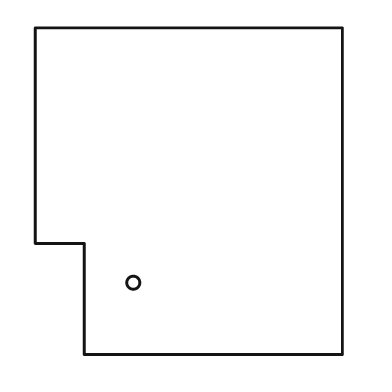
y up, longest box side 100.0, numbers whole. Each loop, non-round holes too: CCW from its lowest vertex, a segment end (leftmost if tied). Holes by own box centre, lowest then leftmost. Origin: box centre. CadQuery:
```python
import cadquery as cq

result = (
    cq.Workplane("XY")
    .moveTo(-32.0, -50.0)
    .lineTo(47.0, -50.0)
    .lineTo(47.0, 50.0)
    .lineTo(-47.0, 50.0)
    .lineTo(-47.0, -16.0)
    .lineTo(-32.0, -16.0)
    .close()
    .moveTo(-17.0, -28.0)
    .circle(2.0)
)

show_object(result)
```